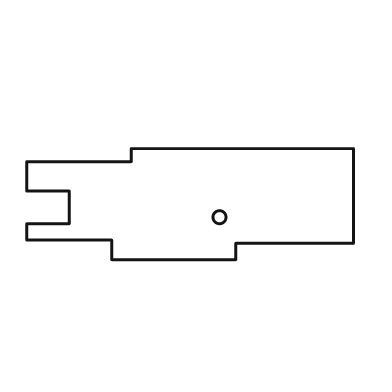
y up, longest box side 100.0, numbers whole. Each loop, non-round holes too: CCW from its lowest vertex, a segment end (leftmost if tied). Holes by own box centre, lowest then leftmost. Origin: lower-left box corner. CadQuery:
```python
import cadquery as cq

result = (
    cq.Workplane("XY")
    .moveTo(26.0, 0.0)
    .lineTo(64.0, 0.0)
    .lineTo(64.0, 5.0)
    .lineTo(100.0, 5.0)
    .lineTo(100.0, 34.0)
    .lineTo(32.0, 34.0)
    .lineTo(32.0, 30.0)
    .lineTo(0.0, 30.0)
    .lineTo(0.0, 21.0)
    .lineTo(13.0, 21.0)
    .lineTo(13.0, 11.0)
    .lineTo(0.0, 11.0)
    .lineTo(0.0, 6.0)
    .lineTo(26.0, 6.0)
    .close()
    .moveTo(59.0, 13.0)
    .circle(2.0)
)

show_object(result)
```